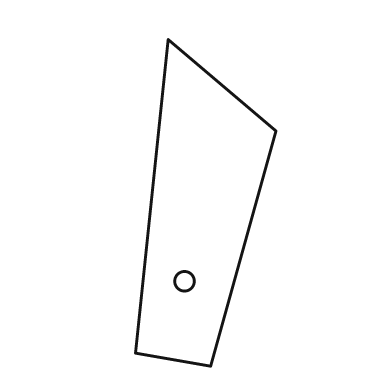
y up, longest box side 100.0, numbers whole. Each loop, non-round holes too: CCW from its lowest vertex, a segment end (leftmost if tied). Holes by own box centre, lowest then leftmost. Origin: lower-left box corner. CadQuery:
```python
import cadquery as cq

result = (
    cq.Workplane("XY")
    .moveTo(23.0, 0.0)
    .lineTo(43.0, 72.0)
    .lineTo(10.0, 100.0)
    .lineTo(0.0, 4.0)
    .close()
    .moveTo(15.0, 26.0)
    .circle(3.0)
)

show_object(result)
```